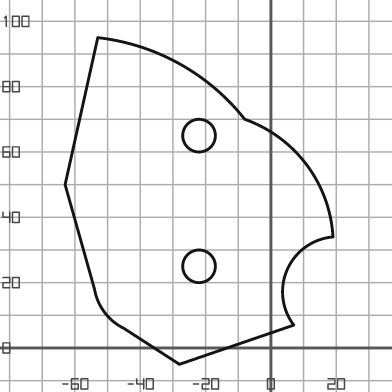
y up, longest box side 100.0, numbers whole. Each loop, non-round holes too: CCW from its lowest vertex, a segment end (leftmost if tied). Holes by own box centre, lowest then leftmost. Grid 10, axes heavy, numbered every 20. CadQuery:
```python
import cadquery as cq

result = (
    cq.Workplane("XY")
    .moveTo(-28.0, -5.0)
    .lineTo(7.0, 7.0)
    .threePointArc((5.0, 24.0), (19.0, 34.0))
    .threePointArc((11.0, 56.0), (-8.0, 70.0))
    .threePointArc((-28.0, 87.0), (-53.0, 95.0))
    .lineTo(-63.0, 50.0)
    .lineTo(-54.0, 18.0)
    .threePointArc((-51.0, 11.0), (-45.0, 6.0))
    .close()
    .moveTo(-22.0, 25.0)
    .circle(5.0)
    .moveTo(-22.0, 65.0)
    .circle(5.0)
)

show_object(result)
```